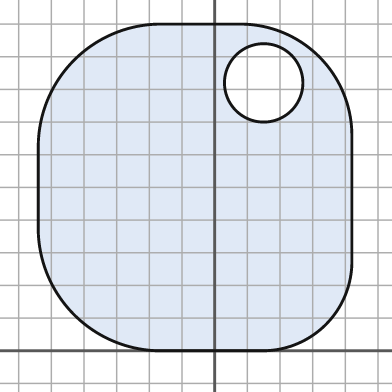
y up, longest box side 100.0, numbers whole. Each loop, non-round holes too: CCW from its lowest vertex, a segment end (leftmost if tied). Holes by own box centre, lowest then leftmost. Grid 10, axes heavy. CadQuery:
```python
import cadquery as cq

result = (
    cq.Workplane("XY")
    .moveTo(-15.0, 0.0)
    .lineTo(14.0, 0.0)
    .threePointArc((34.0, 8.0), (42.0, 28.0))
    .lineTo(42.0, 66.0)
    .threePointArc((32.0, 90.0), (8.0, 100.0))
    .lineTo(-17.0, 100.0)
    .threePointArc((-43.0, 89.0), (-54.0, 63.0))
    .lineTo(-54.0, 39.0)
    .threePointArc((-43.0, 11.0), (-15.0, 0.0))
    .close()
    .moveTo(15.0, 82.0)
    .circle(12.0)
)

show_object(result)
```